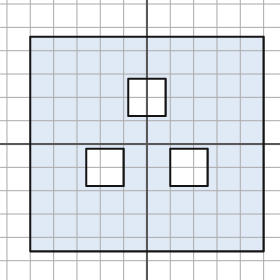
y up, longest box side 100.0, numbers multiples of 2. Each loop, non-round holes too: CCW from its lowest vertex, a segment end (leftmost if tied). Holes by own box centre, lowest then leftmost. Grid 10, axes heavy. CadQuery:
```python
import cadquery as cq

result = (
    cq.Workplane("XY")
    .moveTo(-50.0, -46.0)
    .lineTo(50.0, -46.0)
    .lineTo(50.0, 46.0)
    .lineTo(-50.0, 46.0)
    .close()
    .moveTo(-26.0, -18.0)
    .lineTo(-10.0, -18.0)
    .lineTo(-10.0, -2.0)
    .lineTo(-26.0, -2.0)
    .close()
    .moveTo(10.0, -18.0)
    .lineTo(26.0, -18.0)
    .lineTo(26.0, -2.0)
    .lineTo(10.0, -2.0)
    .close()
    .moveTo(-8.0, 12.0)
    .lineTo(8.0, 12.0)
    .lineTo(8.0, 28.0)
    .lineTo(-8.0, 28.0)
    .close()
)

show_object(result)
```